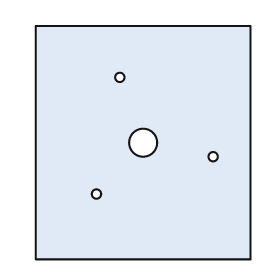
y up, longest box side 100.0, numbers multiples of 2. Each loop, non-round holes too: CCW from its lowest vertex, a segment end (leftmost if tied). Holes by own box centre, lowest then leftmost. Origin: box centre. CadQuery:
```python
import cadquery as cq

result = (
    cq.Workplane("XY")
    .moveTo(-46.0, -50.0)
    .lineTo(46.0, -50.0)
    .lineTo(46.0, 50.0)
    .lineTo(-46.0, 50.0)
    .close()
    .moveTo(-20.0, -22.0)
    .circle(2.0)
    .moveTo(30.0, -6.0)
    .circle(2.0)
    .moveTo(0.0, 0.0)
    .circle(6.0)
    .moveTo(-10.0, 28.0)
    .circle(2.0)
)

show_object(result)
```